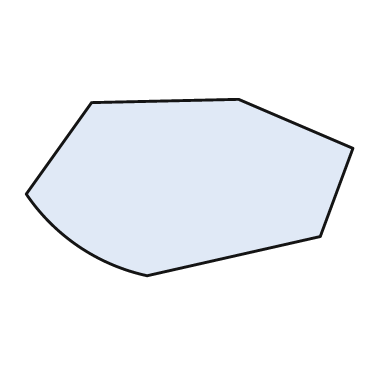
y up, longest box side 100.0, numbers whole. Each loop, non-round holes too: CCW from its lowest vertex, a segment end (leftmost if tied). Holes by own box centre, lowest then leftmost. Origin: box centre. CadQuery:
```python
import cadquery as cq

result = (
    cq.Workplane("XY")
    .moveTo(-13.0, -27.0)
    .lineTo(40.0, -15.0)
    .lineTo(50.0, 12.0)
    .lineTo(15.0, 27.0)
    .lineTo(-30.0, 26.0)
    .lineTo(-50.0, -2.0)
    .threePointArc((-34.0, -18.0), (-13.0, -27.0))
    .close()
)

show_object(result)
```